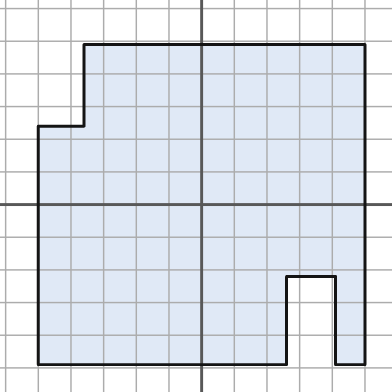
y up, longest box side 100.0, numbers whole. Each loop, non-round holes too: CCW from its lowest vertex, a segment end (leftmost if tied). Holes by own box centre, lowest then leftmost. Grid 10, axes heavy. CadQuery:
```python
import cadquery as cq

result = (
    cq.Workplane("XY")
    .moveTo(-50.0, -49.0)
    .lineTo(26.0, -49.0)
    .lineTo(26.0, -22.0)
    .lineTo(41.0, -22.0)
    .lineTo(41.0, -49.0)
    .lineTo(50.0, -49.0)
    .lineTo(50.0, 49.0)
    .lineTo(-36.0, 49.0)
    .lineTo(-36.0, 24.0)
    .lineTo(-50.0, 24.0)
    .close()
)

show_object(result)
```